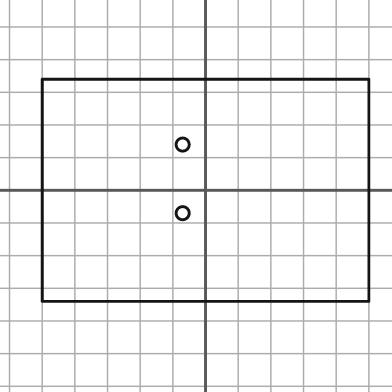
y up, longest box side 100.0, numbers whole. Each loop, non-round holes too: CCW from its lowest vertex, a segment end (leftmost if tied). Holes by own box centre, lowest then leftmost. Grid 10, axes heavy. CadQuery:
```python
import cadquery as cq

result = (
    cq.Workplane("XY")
    .moveTo(-50.0, -34.0)
    .lineTo(50.0, -34.0)
    .lineTo(50.0, 34.0)
    .lineTo(-50.0, 34.0)
    .close()
    .moveTo(-7.0, -7.0)
    .circle(2.0)
    .moveTo(-7.0, 14.0)
    .circle(2.0)
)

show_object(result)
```